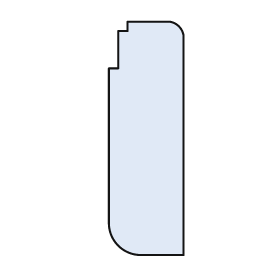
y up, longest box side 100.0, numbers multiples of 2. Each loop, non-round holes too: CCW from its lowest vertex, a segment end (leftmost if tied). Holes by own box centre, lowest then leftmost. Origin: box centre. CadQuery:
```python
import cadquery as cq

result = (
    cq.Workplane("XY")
    .moveTo(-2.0, -50.0)
    .lineTo(16.0, -50.0)
    .lineTo(16.0, 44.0)
    .threePointArc((14.0, 48.0), (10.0, 50.0))
    .lineTo(-8.0, 50.0)
    .lineTo(-8.0, 46.0)
    .lineTo(-12.0, 46.0)
    .lineTo(-12.0, 30.0)
    .lineTo(-16.0, 30.0)
    .lineTo(-16.0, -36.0)
    .threePointArc((-12.0, -46.0), (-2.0, -50.0))
    .close()
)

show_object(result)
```